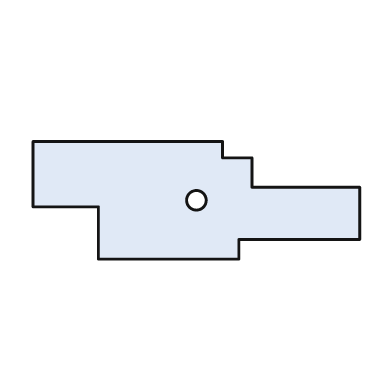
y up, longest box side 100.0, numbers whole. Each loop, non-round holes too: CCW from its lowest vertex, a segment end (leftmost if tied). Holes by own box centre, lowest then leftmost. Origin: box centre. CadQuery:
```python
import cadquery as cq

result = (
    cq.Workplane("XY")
    .moveTo(-30.0, -18.0)
    .lineTo(13.0, -18.0)
    .lineTo(13.0, -12.0)
    .lineTo(50.0, -12.0)
    .lineTo(50.0, 4.0)
    .lineTo(17.0, 4.0)
    .lineTo(17.0, 13.0)
    .lineTo(8.0, 13.0)
    .lineTo(8.0, 18.0)
    .lineTo(-50.0, 18.0)
    .lineTo(-50.0, -2.0)
    .lineTo(-30.0, -2.0)
    .close()
    .moveTo(0.0, 0.0)
    .circle(3.0)
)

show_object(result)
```